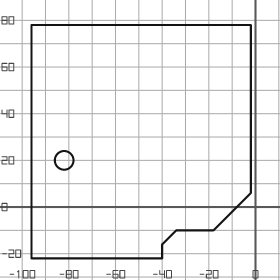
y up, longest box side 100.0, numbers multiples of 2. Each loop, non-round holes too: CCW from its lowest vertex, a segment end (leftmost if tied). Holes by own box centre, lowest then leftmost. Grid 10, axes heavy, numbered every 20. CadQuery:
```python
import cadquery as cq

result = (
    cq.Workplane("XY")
    .moveTo(-96.0, -22.0)
    .lineTo(-40.0, -22.0)
    .lineTo(-40.0, -16.0)
    .lineTo(-34.0, -10.0)
    .lineTo(-18.0, -10.0)
    .lineTo(-2.0, 6.0)
    .lineTo(-2.0, 78.0)
    .lineTo(-96.0, 78.0)
    .close()
    .moveTo(-82.0, 20.0)
    .circle(4.0)
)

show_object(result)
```